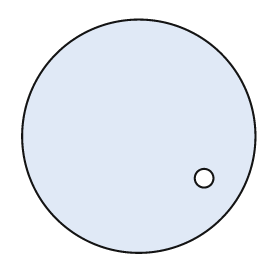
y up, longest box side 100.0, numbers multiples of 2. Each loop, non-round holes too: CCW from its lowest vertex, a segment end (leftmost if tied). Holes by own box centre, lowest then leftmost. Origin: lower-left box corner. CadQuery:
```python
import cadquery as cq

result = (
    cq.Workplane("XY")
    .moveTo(50.0, 50.0)
    .circle(50.0)
    .moveTo(78.0, 32.0)
    .circle(4.0)
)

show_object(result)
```